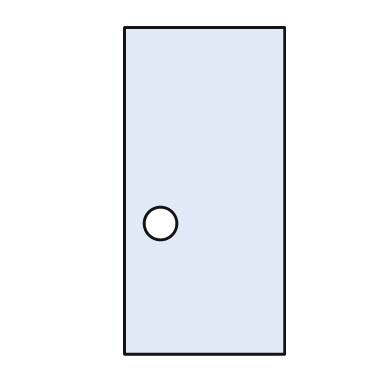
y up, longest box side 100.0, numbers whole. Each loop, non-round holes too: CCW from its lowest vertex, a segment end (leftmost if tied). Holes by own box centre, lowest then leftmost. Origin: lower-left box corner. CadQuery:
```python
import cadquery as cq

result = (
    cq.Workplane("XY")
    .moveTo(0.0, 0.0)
    .lineTo(49.0, 0.0)
    .lineTo(49.0, 100.0)
    .lineTo(0.0, 100.0)
    .close()
    .moveTo(11.0, 40.0)
    .circle(5.0)
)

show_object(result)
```